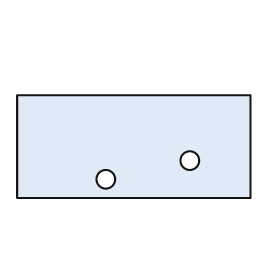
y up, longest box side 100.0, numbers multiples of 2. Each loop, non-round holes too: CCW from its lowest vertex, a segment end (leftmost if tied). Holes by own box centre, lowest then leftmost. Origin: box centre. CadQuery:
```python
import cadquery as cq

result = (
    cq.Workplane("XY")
    .moveTo(-50.0, -22.0)
    .lineTo(50.0, -22.0)
    .lineTo(50.0, 22.0)
    .lineTo(-50.0, 22.0)
    .close()
    .moveTo(-12.0, -14.0)
    .circle(4.0)
    .moveTo(24.0, -6.0)
    .circle(4.0)
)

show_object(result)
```